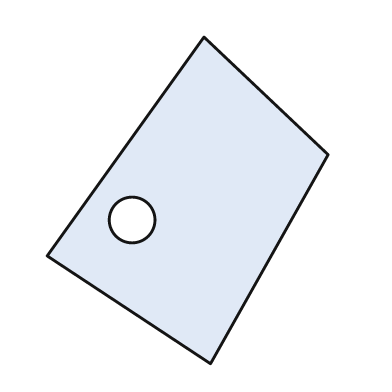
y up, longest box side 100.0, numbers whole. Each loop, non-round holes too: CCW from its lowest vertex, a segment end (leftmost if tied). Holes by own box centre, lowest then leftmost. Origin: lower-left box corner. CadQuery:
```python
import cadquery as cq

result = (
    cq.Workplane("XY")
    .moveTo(50.0, 0.0)
    .lineTo(86.0, 64.0)
    .lineTo(48.0, 100.0)
    .lineTo(0.0, 33.0)
    .close()
    .moveTo(26.0, 44.0)
    .circle(7.0)
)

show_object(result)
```